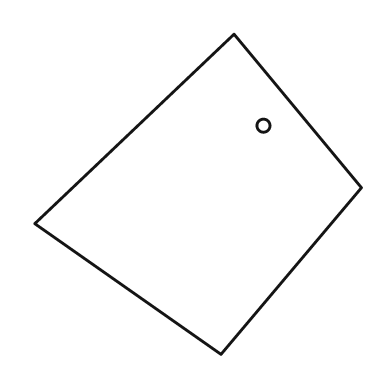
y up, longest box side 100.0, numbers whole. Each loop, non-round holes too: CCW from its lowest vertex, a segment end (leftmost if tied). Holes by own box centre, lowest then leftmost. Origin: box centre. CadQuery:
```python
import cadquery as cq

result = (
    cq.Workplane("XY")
    .moveTo(7.0, -49.0)
    .lineTo(50.0, 2.0)
    .lineTo(11.0, 49.0)
    .lineTo(-50.0, -9.0)
    .close()
    .moveTo(20.0, 21.0)
    .circle(2.0)
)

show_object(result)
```